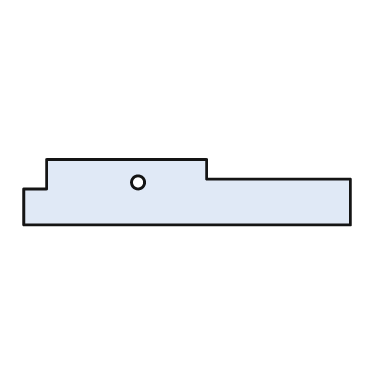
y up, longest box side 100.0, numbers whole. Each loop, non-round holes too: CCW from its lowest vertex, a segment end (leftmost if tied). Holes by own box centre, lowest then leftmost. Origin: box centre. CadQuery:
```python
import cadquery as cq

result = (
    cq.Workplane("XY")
    .moveTo(-50.0, -10.0)
    .lineTo(50.0, -10.0)
    .lineTo(50.0, 4.0)
    .lineTo(6.0, 4.0)
    .lineTo(6.0, 10.0)
    .lineTo(-43.0, 10.0)
    .lineTo(-43.0, 1.0)
    .lineTo(-50.0, 1.0)
    .close()
    .moveTo(-15.0, 3.0)
    .circle(2.0)
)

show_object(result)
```